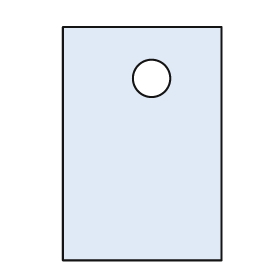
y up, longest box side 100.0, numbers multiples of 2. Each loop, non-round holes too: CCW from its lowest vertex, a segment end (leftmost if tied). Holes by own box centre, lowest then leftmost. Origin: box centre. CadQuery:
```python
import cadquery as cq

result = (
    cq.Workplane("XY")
    .moveTo(-34.0, -50.0)
    .lineTo(34.0, -50.0)
    .lineTo(34.0, 50.0)
    .lineTo(-34.0, 50.0)
    .close()
    .moveTo(4.0, 28.0)
    .circle(8.0)
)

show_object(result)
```